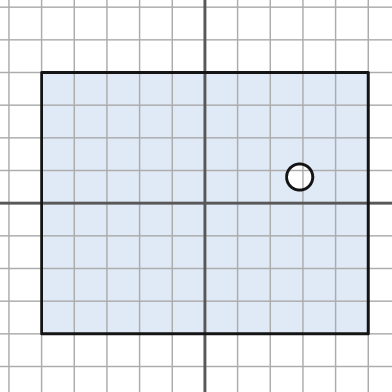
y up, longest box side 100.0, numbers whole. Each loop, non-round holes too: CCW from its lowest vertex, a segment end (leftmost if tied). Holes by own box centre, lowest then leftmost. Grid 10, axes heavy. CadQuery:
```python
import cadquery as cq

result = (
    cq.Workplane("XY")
    .moveTo(-50.0, -40.0)
    .lineTo(50.0, -40.0)
    .lineTo(50.0, 40.0)
    .lineTo(-50.0, 40.0)
    .close()
    .moveTo(29.0, 8.0)
    .circle(4.0)
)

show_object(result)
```